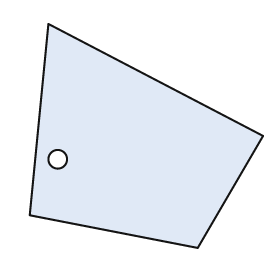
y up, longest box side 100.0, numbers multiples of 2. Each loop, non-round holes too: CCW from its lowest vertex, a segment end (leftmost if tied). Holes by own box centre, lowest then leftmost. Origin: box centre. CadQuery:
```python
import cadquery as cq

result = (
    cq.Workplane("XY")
    .moveTo(22.0, -48.0)
    .lineTo(50.0, 0.0)
    .lineTo(-42.0, 48.0)
    .lineTo(-50.0, -34.0)
    .close()
    .moveTo(-38.0, -10.0)
    .circle(4.0)
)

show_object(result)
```